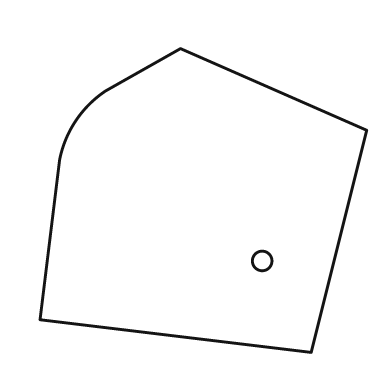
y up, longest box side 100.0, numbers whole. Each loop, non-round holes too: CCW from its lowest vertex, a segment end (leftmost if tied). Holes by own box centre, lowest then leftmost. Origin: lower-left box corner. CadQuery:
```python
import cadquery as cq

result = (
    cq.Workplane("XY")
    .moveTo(83.0, 0.0)
    .lineTo(100.0, 68.0)
    .lineTo(43.0, 93.0)
    .lineTo(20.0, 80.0)
    .threePointArc((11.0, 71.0), (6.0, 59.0))
    .lineTo(0.0, 10.0)
    .close()
    .moveTo(68.0, 28.0)
    .circle(3.0)
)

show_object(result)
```